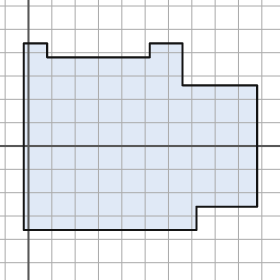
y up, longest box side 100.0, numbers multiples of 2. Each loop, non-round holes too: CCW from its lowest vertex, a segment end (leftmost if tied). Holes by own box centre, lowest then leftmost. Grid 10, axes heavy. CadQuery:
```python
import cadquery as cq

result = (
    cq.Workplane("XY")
    .moveTo(-2.0, -36.0)
    .lineTo(72.0, -36.0)
    .lineTo(72.0, -26.0)
    .lineTo(98.0, -26.0)
    .lineTo(98.0, 26.0)
    .lineTo(66.0, 26.0)
    .lineTo(66.0, 44.0)
    .lineTo(52.0, 44.0)
    .lineTo(52.0, 38.0)
    .lineTo(8.0, 38.0)
    .lineTo(8.0, 44.0)
    .lineTo(-2.0, 44.0)
    .close()
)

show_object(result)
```